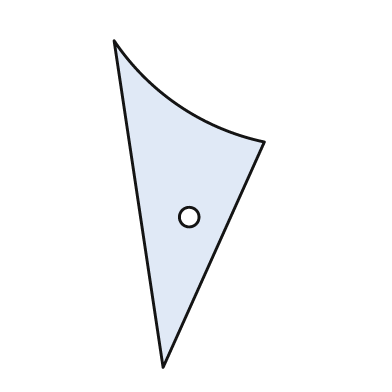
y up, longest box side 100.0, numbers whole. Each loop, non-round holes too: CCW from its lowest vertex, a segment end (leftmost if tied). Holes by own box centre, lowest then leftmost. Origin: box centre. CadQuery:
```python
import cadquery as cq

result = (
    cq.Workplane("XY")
    .moveTo(-8.0, -50.0)
    .lineTo(23.0, 19.0)
    .threePointArc((-3.0, 30.0), (-23.0, 50.0))
    .close()
    .moveTo(0.0, -4.0)
    .circle(3.0)
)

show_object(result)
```